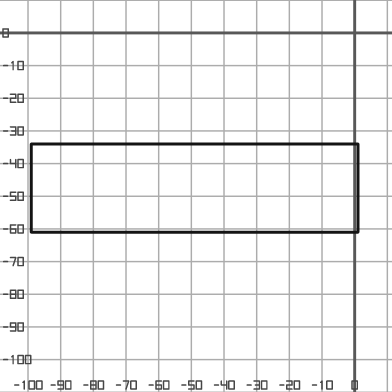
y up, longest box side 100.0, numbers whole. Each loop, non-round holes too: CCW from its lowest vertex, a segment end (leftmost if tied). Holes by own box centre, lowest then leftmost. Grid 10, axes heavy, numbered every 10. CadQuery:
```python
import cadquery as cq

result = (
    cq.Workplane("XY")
    .moveTo(-99.0, -61.0)
    .lineTo(1.0, -61.0)
    .lineTo(1.0, -34.0)
    .lineTo(-99.0, -34.0)
    .close()
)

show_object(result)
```